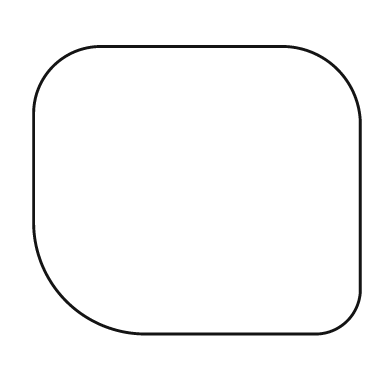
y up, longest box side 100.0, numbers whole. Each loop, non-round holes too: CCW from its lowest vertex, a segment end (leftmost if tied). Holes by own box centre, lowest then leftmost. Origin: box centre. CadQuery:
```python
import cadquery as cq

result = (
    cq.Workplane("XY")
    .moveTo(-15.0, -44.0)
    .lineTo(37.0, -44.0)
    .threePointArc((46.0, -40.0), (50.0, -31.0))
    .lineTo(50.0, 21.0)
    .threePointArc((43.0, 37.0), (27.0, 44.0))
    .lineTo(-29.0, 44.0)
    .threePointArc((-44.0, 38.0), (-50.0, 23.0))
    .lineTo(-50.0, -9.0)
    .threePointArc((-40.0, -34.0), (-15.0, -44.0))
    .close()
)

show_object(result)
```